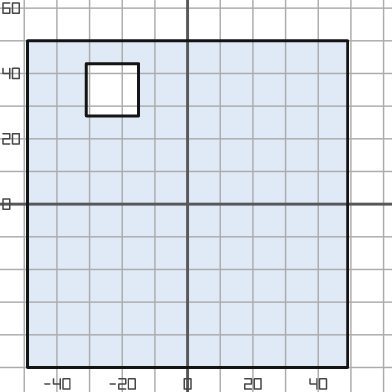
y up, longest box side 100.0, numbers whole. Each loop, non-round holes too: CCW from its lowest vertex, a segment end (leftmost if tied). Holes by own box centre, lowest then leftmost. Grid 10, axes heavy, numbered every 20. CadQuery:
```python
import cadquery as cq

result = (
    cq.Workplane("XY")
    .moveTo(-49.0, -50.0)
    .lineTo(49.0, -50.0)
    .lineTo(49.0, 50.0)
    .lineTo(-49.0, 50.0)
    .close()
    .moveTo(-31.0, 27.0)
    .lineTo(-15.0, 27.0)
    .lineTo(-15.0, 43.0)
    .lineTo(-31.0, 43.0)
    .close()
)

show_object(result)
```